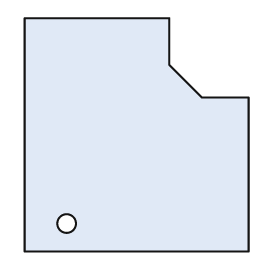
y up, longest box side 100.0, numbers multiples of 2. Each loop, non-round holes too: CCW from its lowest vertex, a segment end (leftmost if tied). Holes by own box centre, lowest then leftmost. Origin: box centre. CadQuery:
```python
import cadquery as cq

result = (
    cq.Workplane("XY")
    .moveTo(-48.0, -50.0)
    .lineTo(48.0, -50.0)
    .lineTo(48.0, 16.0)
    .lineTo(28.0, 16.0)
    .lineTo(14.0, 30.0)
    .lineTo(14.0, 50.0)
    .lineTo(-48.0, 50.0)
    .close()
    .moveTo(-30.0, -38.0)
    .circle(4.0)
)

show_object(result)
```